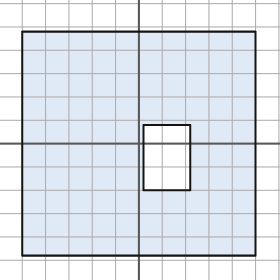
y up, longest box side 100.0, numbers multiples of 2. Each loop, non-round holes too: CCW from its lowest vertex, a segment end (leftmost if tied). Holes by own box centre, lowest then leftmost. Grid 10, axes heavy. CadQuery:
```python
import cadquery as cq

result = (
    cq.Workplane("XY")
    .moveTo(-50.0, -48.0)
    .lineTo(50.0, -48.0)
    .lineTo(50.0, 48.0)
    .lineTo(-50.0, 48.0)
    .close()
    .moveTo(2.0, -20.0)
    .lineTo(22.0, -20.0)
    .lineTo(22.0, 8.0)
    .lineTo(2.0, 8.0)
    .close()
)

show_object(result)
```